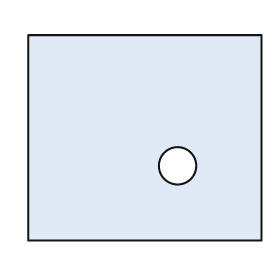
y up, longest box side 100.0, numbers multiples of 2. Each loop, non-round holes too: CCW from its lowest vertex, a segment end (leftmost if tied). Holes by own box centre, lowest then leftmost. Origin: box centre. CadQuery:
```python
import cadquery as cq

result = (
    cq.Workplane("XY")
    .moveTo(-50.0, -44.0)
    .lineTo(50.0, -44.0)
    .lineTo(50.0, 44.0)
    .lineTo(-50.0, 44.0)
    .close()
    .moveTo(14.0, -12.0)
    .circle(8.0)
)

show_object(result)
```